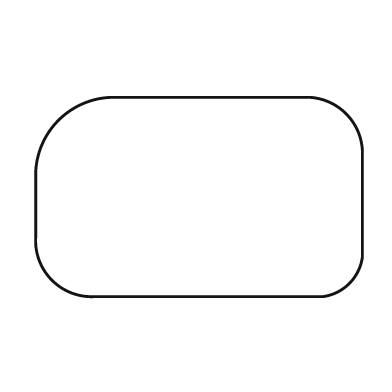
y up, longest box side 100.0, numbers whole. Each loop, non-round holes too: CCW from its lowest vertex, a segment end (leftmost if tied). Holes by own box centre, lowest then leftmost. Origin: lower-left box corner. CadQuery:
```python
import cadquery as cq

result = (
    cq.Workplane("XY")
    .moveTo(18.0, 0.0)
    .lineTo(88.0, 0.0)
    .threePointArc((96.0, 4.0), (100.0, 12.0))
    .lineTo(100.0, 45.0)
    .threePointArc((95.0, 56.0), (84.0, 61.0))
    .lineTo(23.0, 61.0)
    .threePointArc((7.0, 54.0), (0.0, 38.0))
    .lineTo(0.0, 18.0)
    .threePointArc((5.0, 5.0), (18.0, 0.0))
    .close()
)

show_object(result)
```